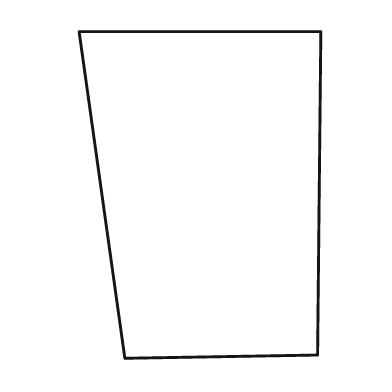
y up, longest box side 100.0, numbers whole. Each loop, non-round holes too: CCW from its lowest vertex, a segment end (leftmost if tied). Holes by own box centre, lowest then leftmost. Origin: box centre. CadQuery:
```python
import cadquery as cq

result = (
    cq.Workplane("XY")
    .moveTo(-23.0, -50.0)
    .lineTo(36.0, -49.0)
    .lineTo(37.0, 50.0)
    .lineTo(-37.0, 50.0)
    .close()
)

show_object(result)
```